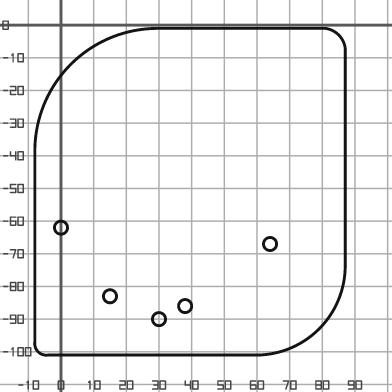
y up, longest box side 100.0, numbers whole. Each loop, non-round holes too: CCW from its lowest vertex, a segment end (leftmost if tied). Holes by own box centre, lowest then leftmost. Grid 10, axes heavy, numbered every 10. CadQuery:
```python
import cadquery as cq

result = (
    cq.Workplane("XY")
    .moveTo(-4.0, -101.0)
    .lineTo(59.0, -101.0)
    .threePointArc((79.0, -93.0), (87.0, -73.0))
    .lineTo(87.0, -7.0)
    .threePointArc((85.0, -3.0), (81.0, -1.0))
    .lineTo(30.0, -1.0)
    .threePointArc((3.0, -12.0), (-8.0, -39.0))
    .lineTo(-8.0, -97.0)
    .threePointArc((-7.0, -100.0), (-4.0, -101.0))
    .close()
    .moveTo(30.0, -90.0)
    .circle(2.0)
    .moveTo(38.0, -86.0)
    .circle(2.0)
    .moveTo(15.0, -83.0)
    .circle(2.0)
    .moveTo(64.0, -67.0)
    .circle(2.0)
    .moveTo(0.0, -62.0)
    .circle(2.0)
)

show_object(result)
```